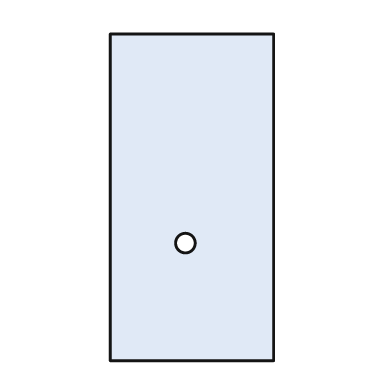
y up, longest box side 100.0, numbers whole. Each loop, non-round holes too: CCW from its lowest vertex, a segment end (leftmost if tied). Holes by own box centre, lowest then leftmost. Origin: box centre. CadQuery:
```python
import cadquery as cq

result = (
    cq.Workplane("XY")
    .moveTo(-25.0, -50.0)
    .lineTo(25.0, -50.0)
    .lineTo(25.0, 50.0)
    .lineTo(-25.0, 50.0)
    .close()
    .moveTo(-2.0, -14.0)
    .circle(3.0)
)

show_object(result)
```